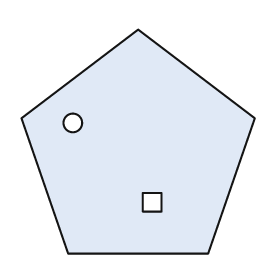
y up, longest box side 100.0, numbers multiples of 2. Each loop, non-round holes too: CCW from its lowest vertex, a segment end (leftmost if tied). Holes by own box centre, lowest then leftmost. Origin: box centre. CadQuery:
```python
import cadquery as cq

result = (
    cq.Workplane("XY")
    .moveTo(-30.0, -48.0)
    .lineTo(30.0, -48.0)
    .lineTo(50.0, 10.0)
    .lineTo(0.0, 48.0)
    .lineTo(-50.0, 10.0)
    .close()
    .moveTo(2.0, -30.0)
    .lineTo(10.0, -30.0)
    .lineTo(10.0, -22.0)
    .lineTo(2.0, -22.0)
    .close()
    .moveTo(-28.0, 8.0)
    .circle(4.0)
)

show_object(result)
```